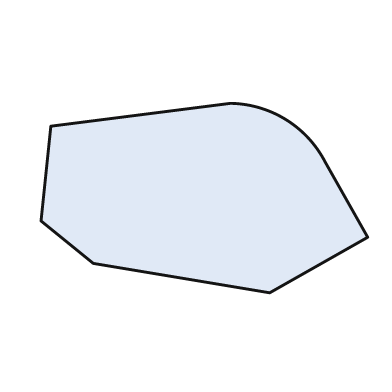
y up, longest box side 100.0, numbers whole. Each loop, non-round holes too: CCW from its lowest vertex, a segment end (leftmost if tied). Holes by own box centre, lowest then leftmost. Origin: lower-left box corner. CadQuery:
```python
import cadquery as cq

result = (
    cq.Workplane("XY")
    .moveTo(70.0, 0.0)
    .lineTo(100.0, 17.0)
    .lineTo(87.0, 40.0)
    .threePointArc((75.0, 53.0), (58.0, 58.0))
    .lineTo(3.0, 51.0)
    .lineTo(0.0, 22.0)
    .lineTo(16.0, 9.0)
    .close()
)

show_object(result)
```